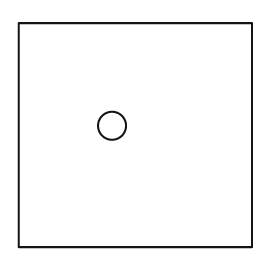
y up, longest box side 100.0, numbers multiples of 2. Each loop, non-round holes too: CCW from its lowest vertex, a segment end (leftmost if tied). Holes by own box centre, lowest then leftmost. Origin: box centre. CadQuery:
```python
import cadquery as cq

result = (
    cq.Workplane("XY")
    .moveTo(-50.0, -48.0)
    .lineTo(50.0, -48.0)
    .lineTo(50.0, 48.0)
    .lineTo(-50.0, 48.0)
    .close()
    .moveTo(-10.0, 4.0)
    .circle(6.0)
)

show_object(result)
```